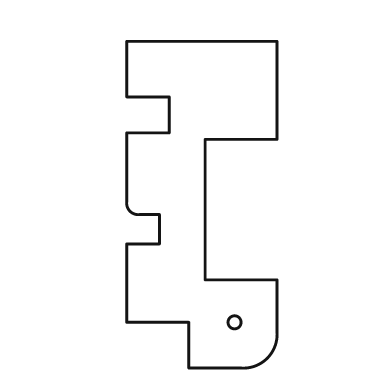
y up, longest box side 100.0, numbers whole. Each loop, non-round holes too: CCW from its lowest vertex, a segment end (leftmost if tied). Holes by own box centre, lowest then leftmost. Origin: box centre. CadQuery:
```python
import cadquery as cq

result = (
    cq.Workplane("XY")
    .moveTo(-4.0, -50.0)
    .lineTo(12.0, -50.0)
    .threePointArc((20.0, -47.0), (23.0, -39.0))
    .lineTo(23.0, -23.0)
    .lineTo(1.0, -23.0)
    .lineTo(1.0, 20.0)
    .lineTo(23.0, 20.0)
    .lineTo(23.0, 50.0)
    .lineTo(-23.0, 50.0)
    .lineTo(-23.0, 33.0)
    .lineTo(-10.0, 33.0)
    .lineTo(-10.0, 22.0)
    .lineTo(-23.0, 22.0)
    .lineTo(-23.0, 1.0)
    .threePointArc((-22.0, -2.0), (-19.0, -3.0))
    .lineTo(-13.0, -3.0)
    .lineTo(-13.0, -12.0)
    .lineTo(-23.0, -12.0)
    .lineTo(-23.0, -36.0)
    .lineTo(-4.0, -36.0)
    .close()
    .moveTo(10.0, -36.0)
    .circle(2.0)
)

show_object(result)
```